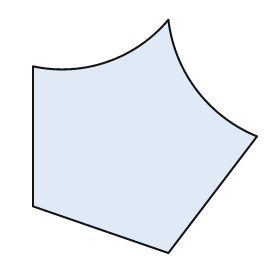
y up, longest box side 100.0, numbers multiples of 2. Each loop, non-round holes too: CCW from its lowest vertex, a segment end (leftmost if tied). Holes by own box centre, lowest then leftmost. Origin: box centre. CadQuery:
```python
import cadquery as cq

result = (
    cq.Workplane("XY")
    .moveTo(10.0, -50.0)
    .lineTo(48.0, 0.0)
    .threePointArc((22.0, 20.0), (10.0, 50.0))
    .threePointArc((-16.0, 32.0), (-48.0, 30.0))
    .lineTo(-48.0, -30.0)
    .close()
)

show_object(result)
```